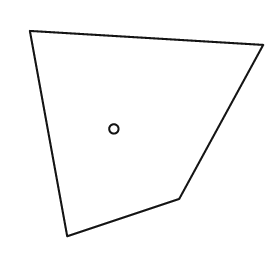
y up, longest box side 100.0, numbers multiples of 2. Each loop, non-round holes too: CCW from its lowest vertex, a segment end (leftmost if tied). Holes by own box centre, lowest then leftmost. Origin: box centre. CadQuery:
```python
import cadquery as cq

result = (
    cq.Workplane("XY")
    .moveTo(-34.0, -44.0)
    .lineTo(14.0, -28.0)
    .lineTo(50.0, 38.0)
    .lineTo(-50.0, 44.0)
    .close()
    .moveTo(-14.0, 2.0)
    .circle(2.0)
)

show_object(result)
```